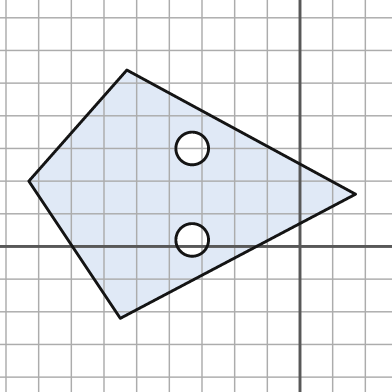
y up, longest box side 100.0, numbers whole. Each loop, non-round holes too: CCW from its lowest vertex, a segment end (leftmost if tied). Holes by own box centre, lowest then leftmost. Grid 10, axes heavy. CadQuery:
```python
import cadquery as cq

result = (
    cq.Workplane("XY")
    .moveTo(-55.0, -22.0)
    .lineTo(17.0, 16.0)
    .lineTo(-53.0, 54.0)
    .lineTo(-83.0, 20.0)
    .close()
    .moveTo(-33.0, 2.0)
    .circle(5.0)
    .moveTo(-33.0, 30.0)
    .circle(5.0)
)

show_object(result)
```